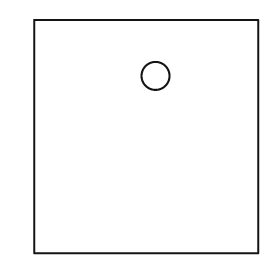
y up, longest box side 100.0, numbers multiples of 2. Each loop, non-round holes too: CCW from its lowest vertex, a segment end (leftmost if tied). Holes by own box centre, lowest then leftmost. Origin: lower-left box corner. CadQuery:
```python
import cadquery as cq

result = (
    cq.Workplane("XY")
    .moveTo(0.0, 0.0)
    .lineTo(96.0, 0.0)
    .lineTo(96.0, 100.0)
    .lineTo(0.0, 100.0)
    .close()
    .moveTo(52.0, 76.0)
    .circle(6.0)
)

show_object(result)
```